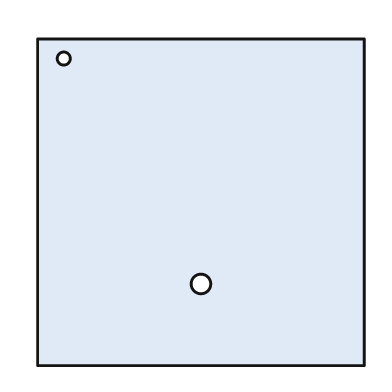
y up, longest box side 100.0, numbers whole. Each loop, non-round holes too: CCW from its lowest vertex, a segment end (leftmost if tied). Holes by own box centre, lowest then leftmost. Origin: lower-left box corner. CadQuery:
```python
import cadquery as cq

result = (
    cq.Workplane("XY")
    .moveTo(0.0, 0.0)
    .lineTo(100.0, 0.0)
    .lineTo(100.0, 100.0)
    .lineTo(0.0, 100.0)
    .close()
    .moveTo(50.0, 25.0)
    .circle(3.0)
    .moveTo(8.0, 94.0)
    .circle(2.0)
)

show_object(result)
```